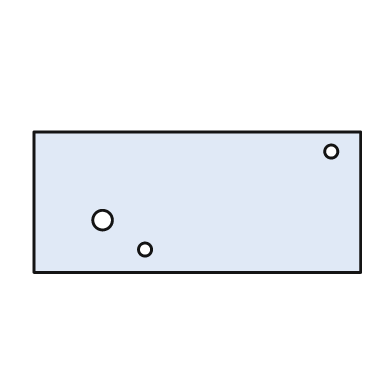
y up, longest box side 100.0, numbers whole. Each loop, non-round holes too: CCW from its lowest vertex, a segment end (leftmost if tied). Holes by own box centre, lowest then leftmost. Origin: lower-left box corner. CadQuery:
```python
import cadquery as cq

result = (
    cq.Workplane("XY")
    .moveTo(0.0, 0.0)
    .lineTo(100.0, 0.0)
    .lineTo(100.0, 43.0)
    .lineTo(0.0, 43.0)
    .close()
    .moveTo(34.0, 7.0)
    .circle(2.0)
    .moveTo(21.0, 16.0)
    .circle(3.0)
    .moveTo(91.0, 37.0)
    .circle(2.0)
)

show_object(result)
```